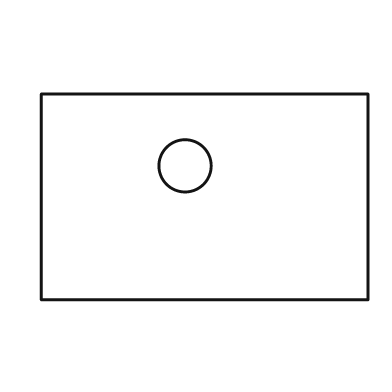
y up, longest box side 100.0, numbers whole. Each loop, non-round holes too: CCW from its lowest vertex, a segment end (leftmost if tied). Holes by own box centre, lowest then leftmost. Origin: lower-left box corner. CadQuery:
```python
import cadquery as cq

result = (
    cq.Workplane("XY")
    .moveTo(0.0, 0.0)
    .lineTo(100.0, 0.0)
    .lineTo(100.0, 63.0)
    .lineTo(0.0, 63.0)
    .close()
    .moveTo(44.0, 41.0)
    .circle(8.0)
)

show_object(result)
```